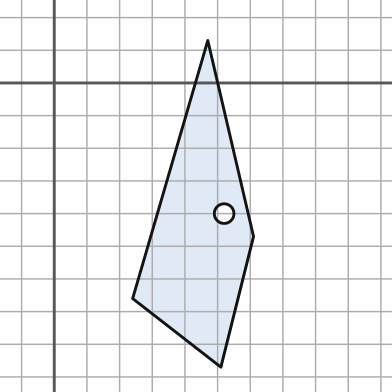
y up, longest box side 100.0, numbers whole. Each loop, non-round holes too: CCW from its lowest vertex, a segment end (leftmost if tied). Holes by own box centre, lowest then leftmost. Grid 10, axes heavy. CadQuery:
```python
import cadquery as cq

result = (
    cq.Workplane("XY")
    .moveTo(51.0, -87.0)
    .lineTo(61.0, -47.0)
    .lineTo(47.0, 13.0)
    .lineTo(24.0, -66.0)
    .close()
    .moveTo(52.0, -40.0)
    .circle(3.0)
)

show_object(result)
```